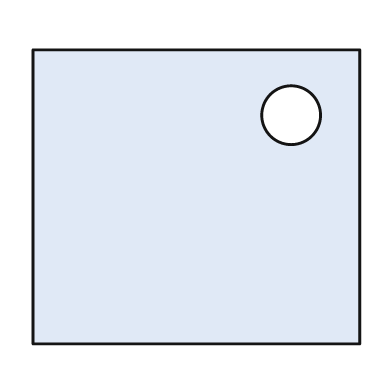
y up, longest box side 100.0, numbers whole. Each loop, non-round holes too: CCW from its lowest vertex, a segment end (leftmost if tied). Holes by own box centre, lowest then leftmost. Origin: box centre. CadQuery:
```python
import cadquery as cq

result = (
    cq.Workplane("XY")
    .moveTo(-50.0, -45.0)
    .lineTo(50.0, -45.0)
    .lineTo(50.0, 45.0)
    .lineTo(-50.0, 45.0)
    .close()
    .moveTo(29.0, 25.0)
    .circle(9.0)
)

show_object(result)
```